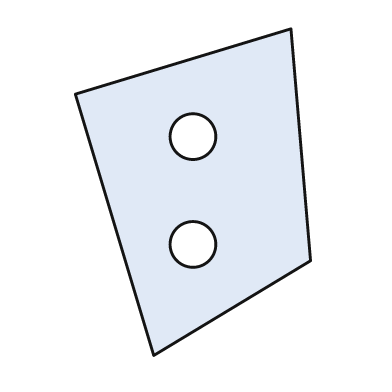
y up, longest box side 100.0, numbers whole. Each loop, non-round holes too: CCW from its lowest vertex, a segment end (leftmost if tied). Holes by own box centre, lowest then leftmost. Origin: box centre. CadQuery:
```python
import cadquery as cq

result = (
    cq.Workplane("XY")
    .moveTo(-12.0, -50.0)
    .lineTo(36.0, -21.0)
    .lineTo(30.0, 50.0)
    .lineTo(-36.0, 30.0)
    .close()
    .moveTo(0.0, -16.0)
    .circle(7.0)
    .moveTo(0.0, 17.0)
    .circle(7.0)
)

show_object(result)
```